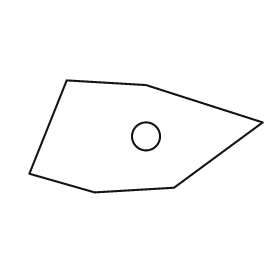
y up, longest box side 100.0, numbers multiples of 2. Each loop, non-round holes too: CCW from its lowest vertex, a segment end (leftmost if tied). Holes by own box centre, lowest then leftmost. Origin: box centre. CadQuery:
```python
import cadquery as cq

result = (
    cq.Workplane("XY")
    .moveTo(-22.0, -24.0)
    .lineTo(12.0, -22.0)
    .lineTo(50.0, 6.0)
    .lineTo(0.0, 22.0)
    .lineTo(-34.0, 24.0)
    .lineTo(-50.0, -16.0)
    .close()
    .moveTo(0.0, 0.0)
    .circle(6.0)
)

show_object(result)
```